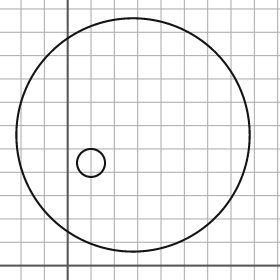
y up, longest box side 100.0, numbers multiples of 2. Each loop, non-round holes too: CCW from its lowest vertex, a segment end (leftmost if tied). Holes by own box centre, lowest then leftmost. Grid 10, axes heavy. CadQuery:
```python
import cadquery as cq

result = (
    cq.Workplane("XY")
    .moveTo(28.0, 56.0)
    .circle(50.0)
    .moveTo(10.0, 44.0)
    .circle(6.0)
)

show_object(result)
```